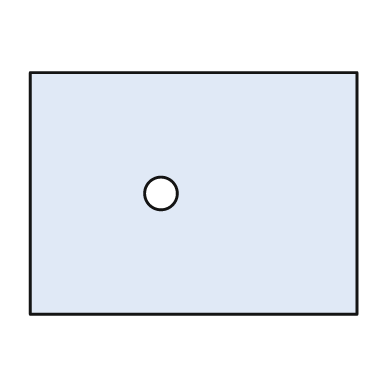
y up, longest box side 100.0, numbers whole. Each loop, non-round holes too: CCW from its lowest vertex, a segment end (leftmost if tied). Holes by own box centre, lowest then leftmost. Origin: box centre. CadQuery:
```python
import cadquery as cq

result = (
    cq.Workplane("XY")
    .moveTo(-50.0, -37.0)
    .lineTo(50.0, -37.0)
    .lineTo(50.0, 37.0)
    .lineTo(-50.0, 37.0)
    .close()
    .moveTo(-10.0, 0.0)
    .circle(5.0)
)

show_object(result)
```